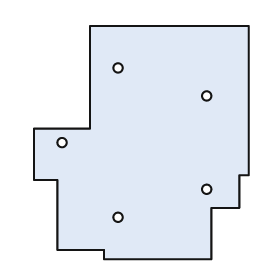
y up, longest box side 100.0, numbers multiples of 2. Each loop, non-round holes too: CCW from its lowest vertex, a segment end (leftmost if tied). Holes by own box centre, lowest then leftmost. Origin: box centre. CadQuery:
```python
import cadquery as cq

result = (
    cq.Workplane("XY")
    .moveTo(-16.0, -50.0)
    .lineTo(30.0, -50.0)
    .lineTo(30.0, -28.0)
    .lineTo(42.0, -28.0)
    .lineTo(42.0, -14.0)
    .lineTo(46.0, -14.0)
    .lineTo(46.0, 50.0)
    .lineTo(-22.0, 50.0)
    .lineTo(-22.0, 6.0)
    .lineTo(-46.0, 6.0)
    .lineTo(-46.0, -16.0)
    .lineTo(-36.0, -16.0)
    .lineTo(-36.0, -46.0)
    .lineTo(-16.0, -46.0)
    .close()
    .moveTo(-10.0, -32.0)
    .circle(2.0)
    .moveTo(28.0, -20.0)
    .circle(2.0)
    .moveTo(-34.0, 0.0)
    .circle(2.0)
    .moveTo(28.0, 20.0)
    .circle(2.0)
    .moveTo(-10.0, 32.0)
    .circle(2.0)
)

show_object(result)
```